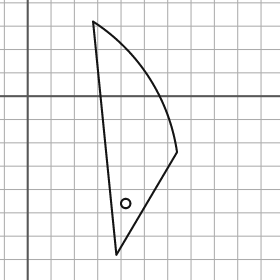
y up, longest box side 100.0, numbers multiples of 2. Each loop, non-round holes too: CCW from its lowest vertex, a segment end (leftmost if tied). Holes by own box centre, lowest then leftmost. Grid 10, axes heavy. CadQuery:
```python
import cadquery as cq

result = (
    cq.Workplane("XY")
    .moveTo(38.0, -68.0)
    .lineTo(64.0, -24.0)
    .threePointArc((52.0, 8.0), (28.0, 32.0))
    .close()
    .moveTo(42.0, -46.0)
    .circle(2.0)
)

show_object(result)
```